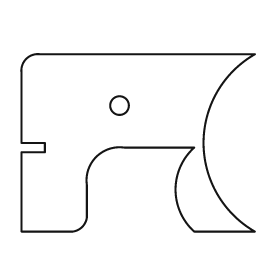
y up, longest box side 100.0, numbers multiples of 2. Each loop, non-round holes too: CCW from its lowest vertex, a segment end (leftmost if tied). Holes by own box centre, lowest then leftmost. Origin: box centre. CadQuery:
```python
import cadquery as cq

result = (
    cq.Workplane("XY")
    .moveTo(-50.0, -38.0)
    .lineTo(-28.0, -38.0)
    .threePointArc((-24.0, -36.0), (-22.0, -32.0))
    .lineTo(-22.0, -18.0)
    .threePointArc((-18.0, -6.0), (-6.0, -2.0))
    .lineTo(24.0, -2.0)
    .threePointArc((16.0, -20.0), (24.0, -38.0))
    .lineTo(50.0, -38.0)
    .threePointArc((28.0, 0.0), (50.0, 38.0))
    .lineTo(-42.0, 38.0)
    .threePointArc((-48.0, 36.0), (-50.0, 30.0))
    .lineTo(-50.0, 0.0)
    .lineTo(-40.0, 0.0)
    .lineTo(-40.0, -4.0)
    .lineTo(-50.0, -4.0)
    .close()
    .moveTo(-8.0, 16.0)
    .circle(4.0)
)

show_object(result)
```